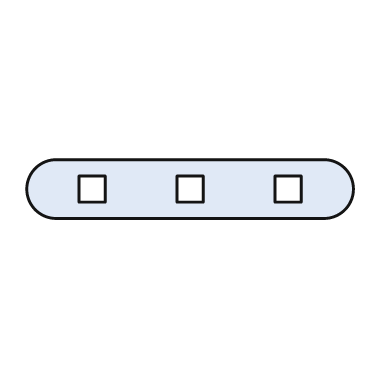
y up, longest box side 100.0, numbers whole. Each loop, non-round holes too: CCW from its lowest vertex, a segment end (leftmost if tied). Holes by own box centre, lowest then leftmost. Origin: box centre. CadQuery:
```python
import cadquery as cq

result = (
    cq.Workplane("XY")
    .moveTo(-41.0, -9.0)
    .lineTo(41.0, -9.0)
    .threePointArc((50.0, 0.0), (41.0, 9.0))
    .lineTo(-41.0, 9.0)
    .threePointArc((-50.0, 0.0), (-41.0, -9.0))
    .close()
    .moveTo(-34.0, -4.0)
    .lineTo(-26.0, -4.0)
    .lineTo(-26.0, 4.0)
    .lineTo(-34.0, 4.0)
    .close()
    .moveTo(-4.0, -4.0)
    .lineTo(4.0, -4.0)
    .lineTo(4.0, 4.0)
    .lineTo(-4.0, 4.0)
    .close()
    .moveTo(26.0, -4.0)
    .lineTo(34.0, -4.0)
    .lineTo(34.0, 4.0)
    .lineTo(26.0, 4.0)
    .close()
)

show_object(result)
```